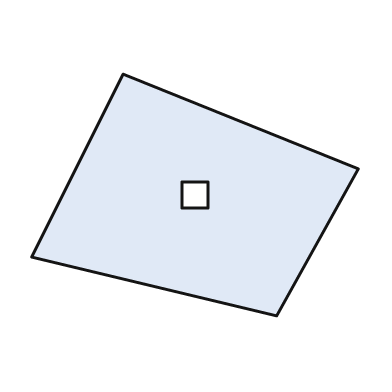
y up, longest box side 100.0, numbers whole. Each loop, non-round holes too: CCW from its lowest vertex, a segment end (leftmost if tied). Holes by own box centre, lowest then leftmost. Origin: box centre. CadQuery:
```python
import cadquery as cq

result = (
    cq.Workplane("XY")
    .moveTo(25.0, -37.0)
    .lineTo(50.0, 8.0)
    .lineTo(-22.0, 37.0)
    .lineTo(-50.0, -19.0)
    .close()
    .moveTo(-4.0, -4.0)
    .lineTo(4.0, -4.0)
    .lineTo(4.0, 4.0)
    .lineTo(-4.0, 4.0)
    .close()
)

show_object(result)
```